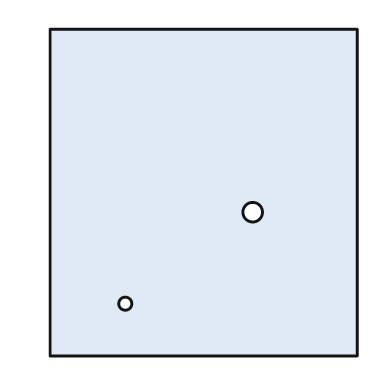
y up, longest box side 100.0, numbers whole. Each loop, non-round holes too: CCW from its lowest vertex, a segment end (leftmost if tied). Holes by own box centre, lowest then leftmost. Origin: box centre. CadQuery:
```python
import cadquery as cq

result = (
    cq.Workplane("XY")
    .moveTo(-47.0, -50.0)
    .lineTo(47.0, -50.0)
    .lineTo(47.0, 50.0)
    .lineTo(-47.0, 50.0)
    .close()
    .moveTo(-24.0, -34.0)
    .circle(2.0)
    .moveTo(15.0, -6.0)
    .circle(3.0)
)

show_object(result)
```